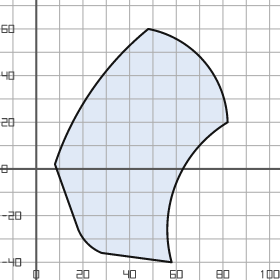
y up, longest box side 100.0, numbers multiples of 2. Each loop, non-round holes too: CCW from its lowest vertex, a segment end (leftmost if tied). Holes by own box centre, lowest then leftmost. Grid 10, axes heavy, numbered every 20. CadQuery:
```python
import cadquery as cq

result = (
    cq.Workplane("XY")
    .moveTo(58.0, -40.0)
    .threePointArc((60.0, -6.0), (82.0, 20.0))
    .threePointArc((72.0, 46.0), (48.0, 60.0))
    .threePointArc((24.0, 34.0), (8.0, 2.0))
    .lineTo(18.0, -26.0)
    .threePointArc((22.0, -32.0), (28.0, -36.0))
    .close()
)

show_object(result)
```